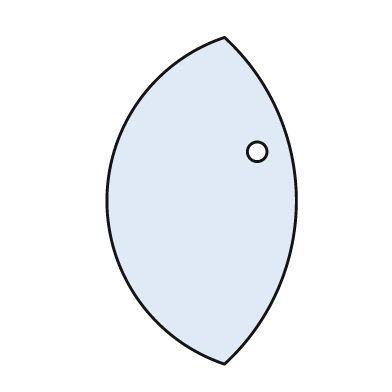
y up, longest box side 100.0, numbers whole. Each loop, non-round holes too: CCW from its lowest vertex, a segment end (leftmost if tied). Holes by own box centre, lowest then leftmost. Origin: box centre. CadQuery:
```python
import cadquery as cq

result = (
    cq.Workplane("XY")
    .moveTo(7.0, -50.0)
    .threePointArc((29.0, 0.0), (7.0, 50.0))
    .threePointArc((-29.0, 0.0), (7.0, -50.0))
    .close()
    .moveTo(17.0, 15.0)
    .circle(3.0)
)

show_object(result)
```